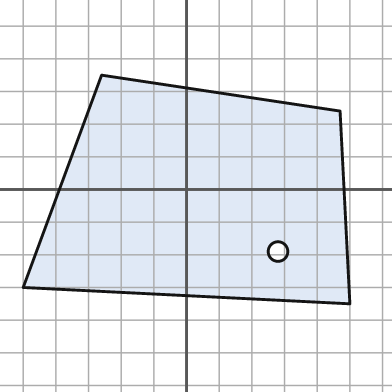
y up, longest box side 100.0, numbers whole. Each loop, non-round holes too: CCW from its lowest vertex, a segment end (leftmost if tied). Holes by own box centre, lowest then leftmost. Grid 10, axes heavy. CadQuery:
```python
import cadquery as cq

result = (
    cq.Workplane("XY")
    .moveTo(50.0, -35.0)
    .lineTo(47.0, 24.0)
    .lineTo(-26.0, 35.0)
    .lineTo(-50.0, -30.0)
    .close()
    .moveTo(28.0, -19.0)
    .circle(3.0)
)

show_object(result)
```